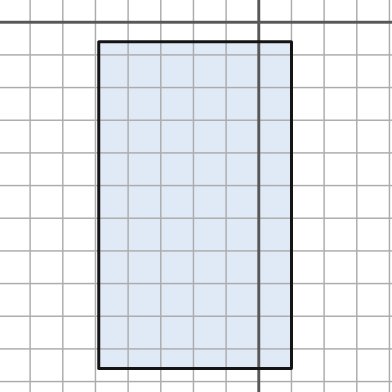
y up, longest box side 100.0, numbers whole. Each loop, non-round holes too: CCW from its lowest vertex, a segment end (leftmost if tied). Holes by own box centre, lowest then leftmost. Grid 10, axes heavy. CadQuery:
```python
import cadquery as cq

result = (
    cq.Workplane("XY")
    .moveTo(-49.0, -106.0)
    .lineTo(10.0, -106.0)
    .lineTo(10.0, -6.0)
    .lineTo(-49.0, -6.0)
    .close()
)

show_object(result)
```